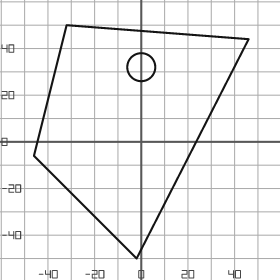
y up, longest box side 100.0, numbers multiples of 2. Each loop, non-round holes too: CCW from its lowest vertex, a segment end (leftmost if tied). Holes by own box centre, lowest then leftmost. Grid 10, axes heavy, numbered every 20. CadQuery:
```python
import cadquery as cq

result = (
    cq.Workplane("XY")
    .moveTo(-2.0, -50.0)
    .lineTo(46.0, 44.0)
    .lineTo(-32.0, 50.0)
    .lineTo(-46.0, -6.0)
    .close()
    .moveTo(0.0, 32.0)
    .circle(6.0)
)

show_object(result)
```